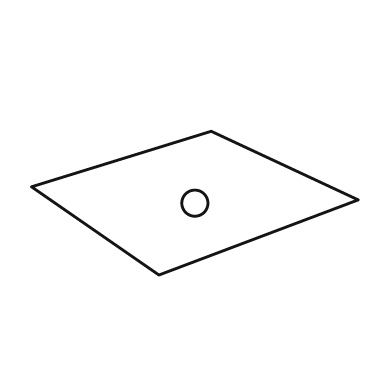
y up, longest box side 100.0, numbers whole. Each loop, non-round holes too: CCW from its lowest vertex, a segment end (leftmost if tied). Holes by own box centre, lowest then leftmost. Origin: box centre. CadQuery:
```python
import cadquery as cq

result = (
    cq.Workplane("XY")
    .moveTo(-11.0, -22.0)
    .lineTo(50.0, 1.0)
    .lineTo(5.0, 22.0)
    .lineTo(-50.0, 5.0)
    .close()
    .moveTo(0.0, 0.0)
    .circle(4.0)
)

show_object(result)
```